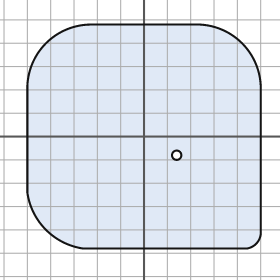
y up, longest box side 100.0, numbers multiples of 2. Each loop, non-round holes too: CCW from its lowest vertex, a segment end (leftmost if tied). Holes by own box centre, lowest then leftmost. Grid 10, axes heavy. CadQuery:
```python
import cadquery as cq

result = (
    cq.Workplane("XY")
    .moveTo(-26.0, -48.0)
    .lineTo(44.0, -48.0)
    .threePointArc((48.0, -46.0), (50.0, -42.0))
    .lineTo(50.0, 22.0)
    .threePointArc((42.0, 40.0), (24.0, 48.0))
    .lineTo(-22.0, 48.0)
    .threePointArc((-42.0, 40.0), (-50.0, 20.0))
    .lineTo(-50.0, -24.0)
    .threePointArc((-42.0, -40.0), (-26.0, -48.0))
    .close()
    .moveTo(14.0, -8.0)
    .circle(2.0)
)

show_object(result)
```